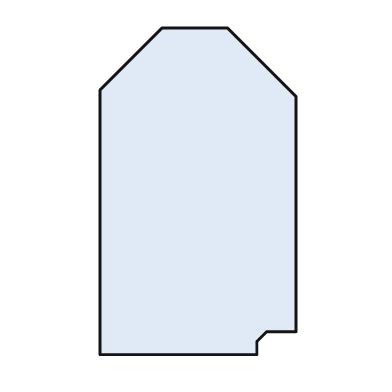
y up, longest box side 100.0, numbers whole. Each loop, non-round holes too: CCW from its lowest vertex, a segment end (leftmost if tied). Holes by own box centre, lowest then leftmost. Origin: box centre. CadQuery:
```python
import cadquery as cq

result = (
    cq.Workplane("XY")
    .moveTo(-30.0, -50.0)
    .lineTo(18.0, -50.0)
    .lineTo(18.0, -46.0)
    .lineTo(21.0, -43.0)
    .lineTo(30.0, -43.0)
    .lineTo(30.0, 29.0)
    .lineTo(9.0, 50.0)
    .lineTo(-11.0, 50.0)
    .lineTo(-30.0, 31.0)
    .close()
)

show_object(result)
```